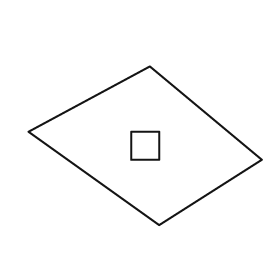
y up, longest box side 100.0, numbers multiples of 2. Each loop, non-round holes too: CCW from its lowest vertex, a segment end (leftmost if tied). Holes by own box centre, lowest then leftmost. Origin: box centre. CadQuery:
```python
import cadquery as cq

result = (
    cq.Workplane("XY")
    .moveTo(6.0, -34.0)
    .lineTo(50.0, -6.0)
    .lineTo(2.0, 34.0)
    .lineTo(-50.0, 6.0)
    .close()
    .moveTo(-6.0, -6.0)
    .lineTo(6.0, -6.0)
    .lineTo(6.0, 6.0)
    .lineTo(-6.0, 6.0)
    .close()
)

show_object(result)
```